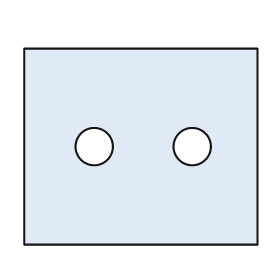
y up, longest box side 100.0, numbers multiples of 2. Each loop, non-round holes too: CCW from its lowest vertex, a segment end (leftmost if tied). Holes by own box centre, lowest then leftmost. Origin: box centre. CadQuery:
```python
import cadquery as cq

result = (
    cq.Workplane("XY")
    .moveTo(-50.0, -42.0)
    .lineTo(50.0, -42.0)
    .lineTo(50.0, 42.0)
    .lineTo(-50.0, 42.0)
    .close()
    .moveTo(-20.0, 0.0)
    .circle(8.0)
    .moveTo(22.0, 0.0)
    .circle(8.0)
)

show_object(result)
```